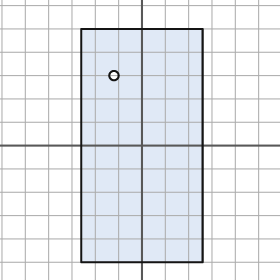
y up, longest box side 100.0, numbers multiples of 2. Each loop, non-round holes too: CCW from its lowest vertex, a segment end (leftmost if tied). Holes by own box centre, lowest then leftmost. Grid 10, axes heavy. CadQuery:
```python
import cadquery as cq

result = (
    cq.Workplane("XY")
    .moveTo(-26.0, -50.0)
    .lineTo(26.0, -50.0)
    .lineTo(26.0, 50.0)
    .lineTo(-26.0, 50.0)
    .close()
    .moveTo(-12.0, 30.0)
    .circle(2.0)
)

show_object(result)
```